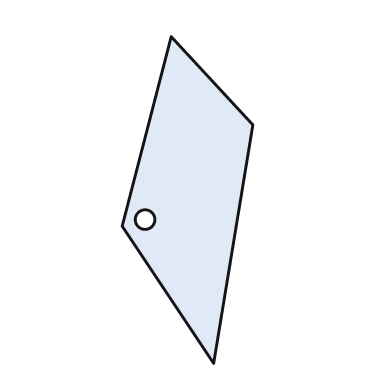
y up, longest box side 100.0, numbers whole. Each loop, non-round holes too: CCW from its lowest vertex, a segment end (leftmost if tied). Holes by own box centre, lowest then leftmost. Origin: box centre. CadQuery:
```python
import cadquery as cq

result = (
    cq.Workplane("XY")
    .moveTo(8.0, -50.0)
    .lineTo(20.0, 23.0)
    .lineTo(-5.0, 50.0)
    .lineTo(-20.0, -8.0)
    .close()
    .moveTo(-13.0, -6.0)
    .circle(3.0)
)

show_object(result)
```